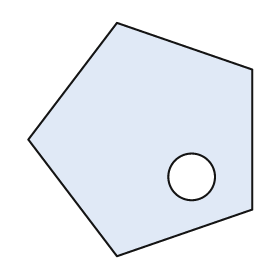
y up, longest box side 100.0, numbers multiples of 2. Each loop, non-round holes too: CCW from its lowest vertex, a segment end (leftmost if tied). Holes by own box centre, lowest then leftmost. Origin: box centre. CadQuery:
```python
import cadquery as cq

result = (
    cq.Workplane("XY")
    .moveTo(-10.0, -50.0)
    .lineTo(48.0, -30.0)
    .lineTo(48.0, 30.0)
    .lineTo(-10.0, 50.0)
    .lineTo(-48.0, 0.0)
    .close()
    .moveTo(22.0, -16.0)
    .circle(10.0)
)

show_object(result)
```